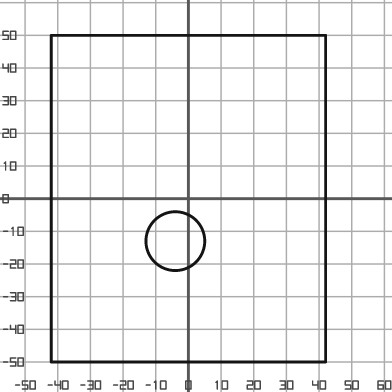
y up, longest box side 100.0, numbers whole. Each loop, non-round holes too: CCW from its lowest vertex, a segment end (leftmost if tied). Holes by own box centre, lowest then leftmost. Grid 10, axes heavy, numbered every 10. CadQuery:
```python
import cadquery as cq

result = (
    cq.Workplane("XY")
    .moveTo(-42.0, -50.0)
    .lineTo(42.0, -50.0)
    .lineTo(42.0, 50.0)
    .lineTo(-42.0, 50.0)
    .close()
    .moveTo(-4.0, -13.0)
    .circle(9.0)
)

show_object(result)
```